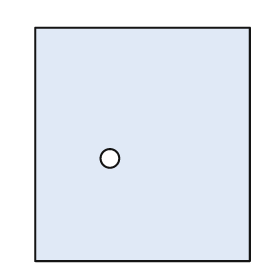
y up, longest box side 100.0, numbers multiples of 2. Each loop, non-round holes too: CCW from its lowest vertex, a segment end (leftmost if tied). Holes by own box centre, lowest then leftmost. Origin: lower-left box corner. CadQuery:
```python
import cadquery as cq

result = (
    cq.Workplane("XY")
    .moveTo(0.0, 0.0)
    .lineTo(92.0, 0.0)
    .lineTo(92.0, 100.0)
    .lineTo(0.0, 100.0)
    .close()
    .moveTo(32.0, 44.0)
    .circle(4.0)
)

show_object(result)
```